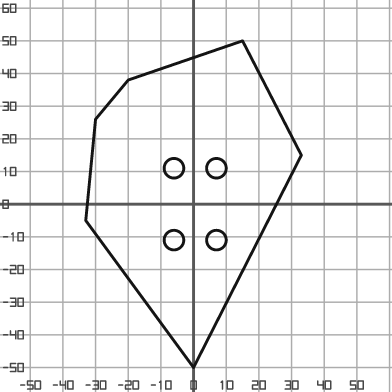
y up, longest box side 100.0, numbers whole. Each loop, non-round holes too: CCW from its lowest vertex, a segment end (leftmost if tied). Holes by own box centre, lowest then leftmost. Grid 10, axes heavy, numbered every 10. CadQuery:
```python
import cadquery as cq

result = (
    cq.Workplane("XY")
    .moveTo(0.0, -50.0)
    .lineTo(33.0, 15.0)
    .lineTo(15.0, 50.0)
    .lineTo(-20.0, 38.0)
    .lineTo(-30.0, 26.0)
    .lineTo(-33.0, -5.0)
    .close()
    .moveTo(-6.0, -11.0)
    .circle(3.0)
    .moveTo(7.0, -11.0)
    .circle(3.0)
    .moveTo(-6.0, 11.0)
    .circle(3.0)
    .moveTo(7.0, 11.0)
    .circle(3.0)
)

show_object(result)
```